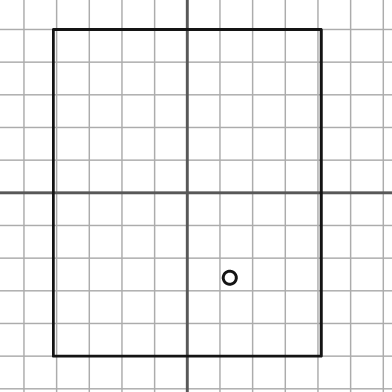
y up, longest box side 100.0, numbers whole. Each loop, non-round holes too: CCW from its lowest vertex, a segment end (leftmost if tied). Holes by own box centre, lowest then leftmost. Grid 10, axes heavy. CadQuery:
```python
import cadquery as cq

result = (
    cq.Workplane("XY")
    .moveTo(-41.0, -50.0)
    .lineTo(41.0, -50.0)
    .lineTo(41.0, 50.0)
    .lineTo(-41.0, 50.0)
    .close()
    .moveTo(13.0, -26.0)
    .circle(2.0)
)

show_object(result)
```